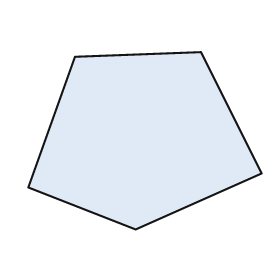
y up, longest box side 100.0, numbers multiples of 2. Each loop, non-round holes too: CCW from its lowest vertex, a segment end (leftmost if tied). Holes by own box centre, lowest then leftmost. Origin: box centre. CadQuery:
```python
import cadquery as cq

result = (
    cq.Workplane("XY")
    .moveTo(-4.0, -38.0)
    .lineTo(50.0, -14.0)
    .lineTo(24.0, 38.0)
    .lineTo(-30.0, 36.0)
    .lineTo(-50.0, -20.0)
    .close()
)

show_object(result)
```